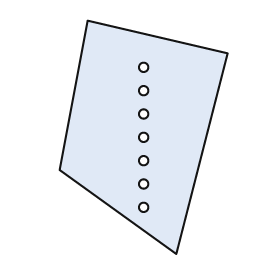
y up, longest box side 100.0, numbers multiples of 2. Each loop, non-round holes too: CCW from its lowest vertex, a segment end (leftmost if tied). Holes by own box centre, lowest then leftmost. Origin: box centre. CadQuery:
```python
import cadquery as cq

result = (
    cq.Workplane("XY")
    .moveTo(14.0, -50.0)
    .lineTo(36.0, 36.0)
    .lineTo(-24.0, 50.0)
    .lineTo(-36.0, -14.0)
    .close()
    .moveTo(0.0, -30.0)
    .circle(2.0)
    .moveTo(0.0, -20.0)
    .circle(2.0)
    .moveTo(0.0, -10.0)
    .circle(2.0)
    .moveTo(0.0, 0.0)
    .circle(2.0)
    .moveTo(0.0, 10.0)
    .circle(2.0)
    .moveTo(0.0, 20.0)
    .circle(2.0)
    .moveTo(0.0, 30.0)
    .circle(2.0)
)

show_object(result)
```